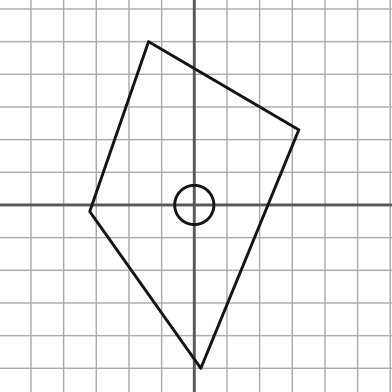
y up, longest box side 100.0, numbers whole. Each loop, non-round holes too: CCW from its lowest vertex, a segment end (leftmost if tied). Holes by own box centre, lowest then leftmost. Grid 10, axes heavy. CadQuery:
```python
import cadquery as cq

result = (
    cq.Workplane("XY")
    .moveTo(2.0, -50.0)
    .lineTo(32.0, 23.0)
    .lineTo(-14.0, 50.0)
    .lineTo(-32.0, -2.0)
    .close()
    .moveTo(0.0, 0.0)
    .circle(6.0)
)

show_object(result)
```